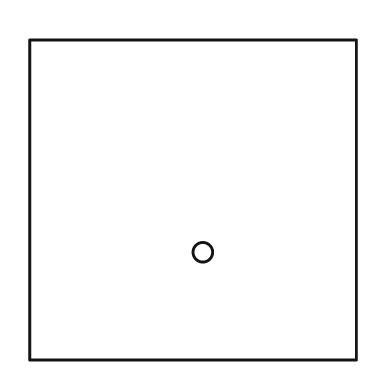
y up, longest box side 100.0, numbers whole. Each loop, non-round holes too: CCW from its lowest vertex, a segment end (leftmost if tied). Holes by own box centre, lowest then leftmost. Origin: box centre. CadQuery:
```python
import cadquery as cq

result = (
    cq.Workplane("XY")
    .moveTo(-50.0, -49.0)
    .lineTo(50.0, -49.0)
    .lineTo(50.0, 49.0)
    .lineTo(-50.0, 49.0)
    .close()
    .moveTo(3.0, -16.0)
    .circle(3.0)
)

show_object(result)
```